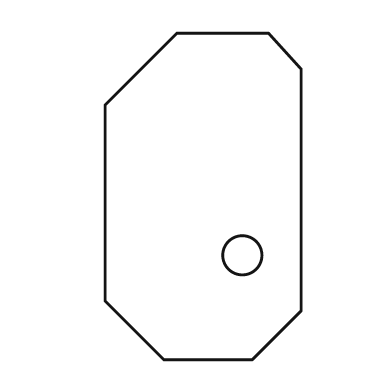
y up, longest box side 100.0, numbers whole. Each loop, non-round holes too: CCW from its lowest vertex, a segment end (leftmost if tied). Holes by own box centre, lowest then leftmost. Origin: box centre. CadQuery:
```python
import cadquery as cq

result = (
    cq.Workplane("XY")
    .moveTo(-12.0, -50.0)
    .lineTo(15.0, -50.0)
    .lineTo(30.0, -35.0)
    .lineTo(30.0, 39.0)
    .lineTo(20.0, 50.0)
    .lineTo(-8.0, 50.0)
    .lineTo(-30.0, 28.0)
    .lineTo(-30.0, -32.0)
    .close()
    .moveTo(12.0, -18.0)
    .circle(6.0)
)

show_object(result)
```